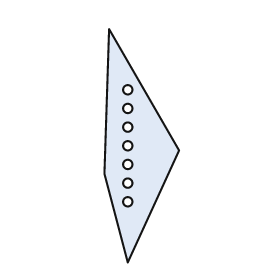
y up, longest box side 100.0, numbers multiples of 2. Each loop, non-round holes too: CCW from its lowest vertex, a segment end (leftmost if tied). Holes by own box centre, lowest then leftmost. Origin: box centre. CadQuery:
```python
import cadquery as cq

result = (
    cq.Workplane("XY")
    .moveTo(-6.0, -50.0)
    .lineTo(16.0, -2.0)
    .lineTo(-14.0, 50.0)
    .lineTo(-16.0, -12.0)
    .close()
    .moveTo(-6.0, -24.0)
    .circle(2.0)
    .moveTo(-6.0, -16.0)
    .circle(2.0)
    .moveTo(-6.0, -8.0)
    .circle(2.0)
    .moveTo(-6.0, 0.0)
    .circle(2.0)
    .moveTo(-6.0, 8.0)
    .circle(2.0)
    .moveTo(-6.0, 16.0)
    .circle(2.0)
    .moveTo(-6.0, 24.0)
    .circle(2.0)
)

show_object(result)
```